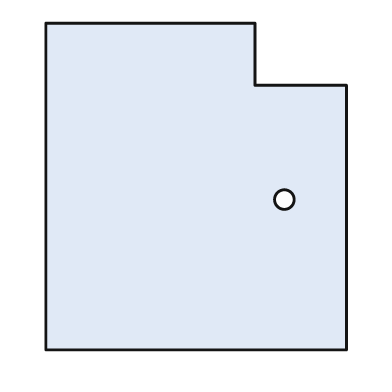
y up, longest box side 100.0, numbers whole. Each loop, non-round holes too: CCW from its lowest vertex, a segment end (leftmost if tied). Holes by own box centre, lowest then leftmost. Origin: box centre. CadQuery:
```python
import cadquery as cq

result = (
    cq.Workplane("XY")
    .moveTo(-46.0, -50.0)
    .lineTo(46.0, -50.0)
    .lineTo(46.0, 31.0)
    .lineTo(18.0, 31.0)
    .lineTo(18.0, 50.0)
    .lineTo(-46.0, 50.0)
    .close()
    .moveTo(27.0, -4.0)
    .circle(3.0)
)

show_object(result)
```